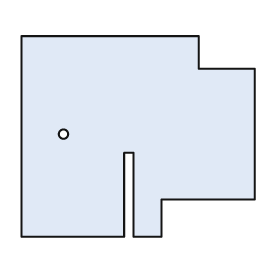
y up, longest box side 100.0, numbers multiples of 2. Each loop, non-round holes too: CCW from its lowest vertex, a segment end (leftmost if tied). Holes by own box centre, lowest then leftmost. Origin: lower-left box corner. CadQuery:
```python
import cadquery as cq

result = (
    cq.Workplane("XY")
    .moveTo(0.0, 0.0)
    .lineTo(44.0, 0.0)
    .lineTo(44.0, 36.0)
    .lineTo(48.0, 36.0)
    .lineTo(48.0, 0.0)
    .lineTo(60.0, 0.0)
    .lineTo(60.0, 16.0)
    .lineTo(100.0, 16.0)
    .lineTo(100.0, 72.0)
    .lineTo(76.0, 72.0)
    .lineTo(76.0, 86.0)
    .lineTo(0.0, 86.0)
    .close()
    .moveTo(18.0, 44.0)
    .circle(2.0)
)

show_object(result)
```